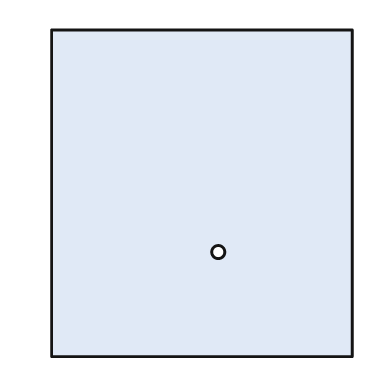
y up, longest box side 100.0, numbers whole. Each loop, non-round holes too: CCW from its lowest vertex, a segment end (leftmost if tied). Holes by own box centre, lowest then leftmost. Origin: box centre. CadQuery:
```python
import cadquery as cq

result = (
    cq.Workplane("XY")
    .moveTo(-46.0, -50.0)
    .lineTo(46.0, -50.0)
    .lineTo(46.0, 50.0)
    .lineTo(-46.0, 50.0)
    .close()
    .moveTo(5.0, -18.0)
    .circle(2.0)
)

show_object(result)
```